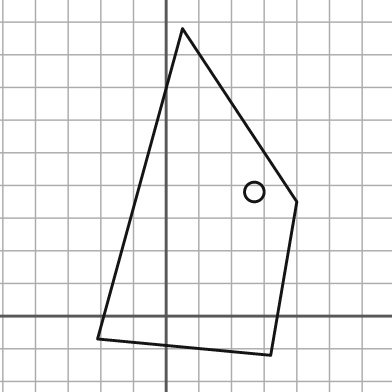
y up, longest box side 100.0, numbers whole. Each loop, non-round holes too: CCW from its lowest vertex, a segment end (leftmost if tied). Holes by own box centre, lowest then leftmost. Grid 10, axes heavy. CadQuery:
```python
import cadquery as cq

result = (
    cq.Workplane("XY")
    .moveTo(32.0, -12.0)
    .lineTo(40.0, 35.0)
    .lineTo(5.0, 88.0)
    .lineTo(-21.0, -7.0)
    .close()
    .moveTo(27.0, 38.0)
    .circle(3.0)
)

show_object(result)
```